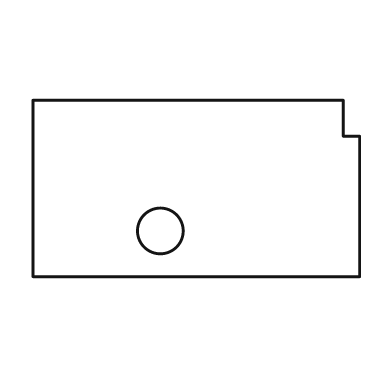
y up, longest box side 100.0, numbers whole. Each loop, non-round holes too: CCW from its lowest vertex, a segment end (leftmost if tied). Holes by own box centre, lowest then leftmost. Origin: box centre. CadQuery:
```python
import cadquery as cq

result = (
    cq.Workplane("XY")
    .moveTo(-50.0, -27.0)
    .lineTo(50.0, -27.0)
    .lineTo(50.0, 16.0)
    .lineTo(45.0, 16.0)
    .lineTo(45.0, 27.0)
    .lineTo(-50.0, 27.0)
    .close()
    .moveTo(-11.0, -13.0)
    .circle(7.0)
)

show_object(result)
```